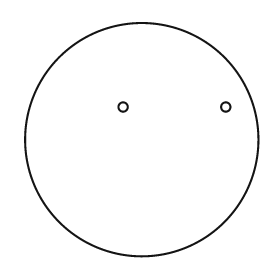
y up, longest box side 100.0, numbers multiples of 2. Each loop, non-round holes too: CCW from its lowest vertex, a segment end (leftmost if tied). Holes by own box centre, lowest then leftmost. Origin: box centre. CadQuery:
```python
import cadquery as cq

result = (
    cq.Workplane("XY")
    .moveTo(0.0, 0.0)
    .circle(50.0)
    .moveTo(-8.0, 14.0)
    .circle(2.0)
    .moveTo(36.0, 14.0)
    .circle(2.0)
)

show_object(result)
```